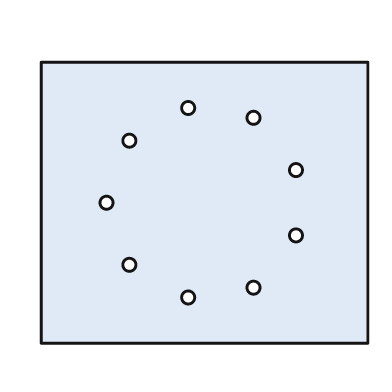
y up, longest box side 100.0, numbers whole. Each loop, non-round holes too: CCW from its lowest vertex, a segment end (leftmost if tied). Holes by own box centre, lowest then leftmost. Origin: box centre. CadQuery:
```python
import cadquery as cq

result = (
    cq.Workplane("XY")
    .moveTo(-50.0, -43.0)
    .lineTo(50.0, -43.0)
    .lineTo(50.0, 43.0)
    .lineTo(-50.0, 43.0)
    .close()
    .moveTo(-5.0, -29.0)
    .circle(2.0)
    .moveTo(15.0, -26.0)
    .circle(2.0)
    .moveTo(-23.0, -19.0)
    .circle(2.0)
    .moveTo(28.0, -10.0)
    .circle(2.0)
    .moveTo(-30.0, 0.0)
    .circle(2.0)
    .moveTo(28.0, 10.0)
    .circle(2.0)
    .moveTo(-23.0, 19.0)
    .circle(2.0)
    .moveTo(15.0, 26.0)
    .circle(2.0)
    .moveTo(-5.0, 29.0)
    .circle(2.0)
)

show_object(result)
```